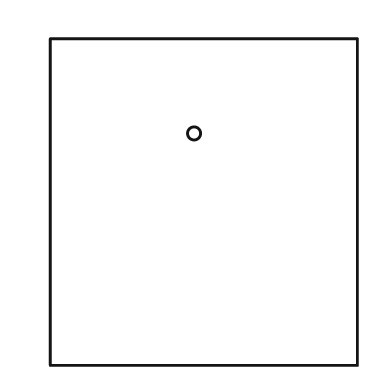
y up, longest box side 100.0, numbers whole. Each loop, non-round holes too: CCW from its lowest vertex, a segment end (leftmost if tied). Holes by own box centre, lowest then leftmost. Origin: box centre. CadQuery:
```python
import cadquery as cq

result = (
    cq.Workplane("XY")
    .moveTo(-47.0, -50.0)
    .lineTo(47.0, -50.0)
    .lineTo(47.0, 50.0)
    .lineTo(-47.0, 50.0)
    .close()
    .moveTo(-3.0, 21.0)
    .circle(2.0)
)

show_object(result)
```